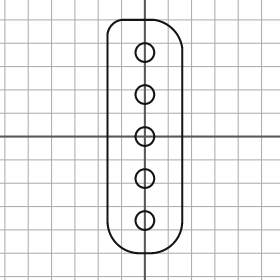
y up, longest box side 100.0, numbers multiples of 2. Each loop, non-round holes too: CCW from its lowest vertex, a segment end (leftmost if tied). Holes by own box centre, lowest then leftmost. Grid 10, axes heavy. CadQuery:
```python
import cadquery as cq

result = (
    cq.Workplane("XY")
    .moveTo(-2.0, -50.0)
    .lineTo(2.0, -50.0)
    .threePointArc((12.0, -46.0), (16.0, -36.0))
    .lineTo(16.0, 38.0)
    .threePointArc((12.0, 46.0), (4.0, 50.0))
    .lineTo(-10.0, 50.0)
    .threePointArc((-14.0, 48.0), (-16.0, 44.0))
    .lineTo(-16.0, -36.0)
    .threePointArc((-12.0, -46.0), (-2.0, -50.0))
    .close()
    .moveTo(0.0, -36.0)
    .circle(4.0)
    .moveTo(0.0, -18.0)
    .circle(4.0)
    .moveTo(0.0, 0.0)
    .circle(4.0)
    .moveTo(0.0, 18.0)
    .circle(4.0)
    .moveTo(0.0, 36.0)
    .circle(4.0)
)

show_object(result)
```